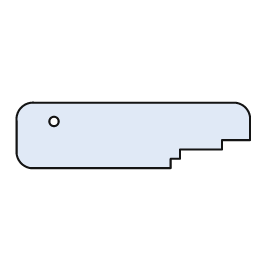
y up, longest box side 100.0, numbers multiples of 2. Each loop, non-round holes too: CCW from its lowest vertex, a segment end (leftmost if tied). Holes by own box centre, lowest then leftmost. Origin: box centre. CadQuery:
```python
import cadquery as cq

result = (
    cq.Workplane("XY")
    .moveTo(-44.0, -14.0)
    .lineTo(16.0, -14.0)
    .lineTo(16.0, -10.0)
    .lineTo(20.0, -10.0)
    .lineTo(20.0, -6.0)
    .lineTo(38.0, -6.0)
    .lineTo(38.0, -2.0)
    .lineTo(50.0, -2.0)
    .lineTo(50.0, 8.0)
    .threePointArc((48.0, 12.0), (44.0, 14.0))
    .lineTo(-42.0, 14.0)
    .threePointArc((-48.0, 12.0), (-50.0, 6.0))
    .lineTo(-50.0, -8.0)
    .threePointArc((-48.0, -12.0), (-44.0, -14.0))
    .close()
    .moveTo(-34.0, 6.0)
    .circle(2.0)
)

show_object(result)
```